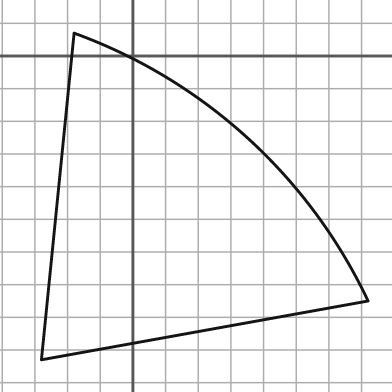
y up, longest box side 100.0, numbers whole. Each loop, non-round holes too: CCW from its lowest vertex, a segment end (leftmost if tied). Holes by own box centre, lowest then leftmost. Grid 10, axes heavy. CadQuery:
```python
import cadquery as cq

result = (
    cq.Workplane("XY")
    .moveTo(-28.0, -93.0)
    .lineTo(72.0, -75.0)
    .threePointArc((35.0, -25.0), (-18.0, 7.0))
    .close()
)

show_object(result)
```